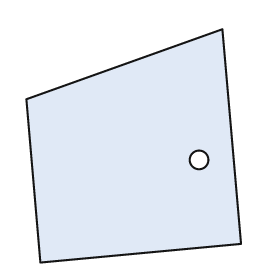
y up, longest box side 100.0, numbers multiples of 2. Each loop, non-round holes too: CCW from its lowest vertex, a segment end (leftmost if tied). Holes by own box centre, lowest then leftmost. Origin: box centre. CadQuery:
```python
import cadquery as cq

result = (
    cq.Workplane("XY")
    .moveTo(-40.0, -50.0)
    .lineTo(46.0, -42.0)
    .lineTo(38.0, 50.0)
    .lineTo(-46.0, 20.0)
    .close()
    .moveTo(28.0, -6.0)
    .circle(4.0)
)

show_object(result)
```